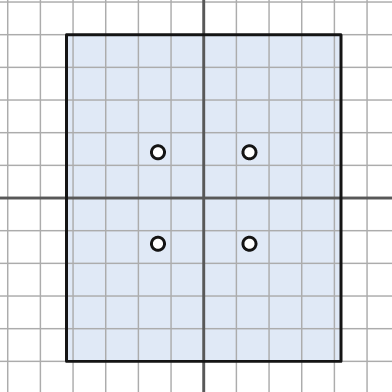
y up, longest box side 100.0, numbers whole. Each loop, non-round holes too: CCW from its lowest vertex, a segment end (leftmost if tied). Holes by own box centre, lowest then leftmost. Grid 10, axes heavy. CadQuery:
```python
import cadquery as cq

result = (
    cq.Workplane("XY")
    .moveTo(-42.0, -50.0)
    .lineTo(42.0, -50.0)
    .lineTo(42.0, 50.0)
    .lineTo(-42.0, 50.0)
    .close()
    .moveTo(-14.0, -14.0)
    .circle(2.0)
    .moveTo(14.0, -14.0)
    .circle(2.0)
    .moveTo(-14.0, 14.0)
    .circle(2.0)
    .moveTo(14.0, 14.0)
    .circle(2.0)
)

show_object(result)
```